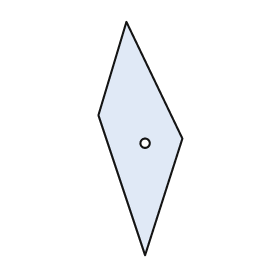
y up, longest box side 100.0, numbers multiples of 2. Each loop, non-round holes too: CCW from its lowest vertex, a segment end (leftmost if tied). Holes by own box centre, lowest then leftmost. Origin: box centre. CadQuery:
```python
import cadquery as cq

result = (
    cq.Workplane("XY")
    .moveTo(2.0, -50.0)
    .lineTo(18.0, 0.0)
    .lineTo(-6.0, 50.0)
    .lineTo(-18.0, 10.0)
    .close()
    .moveTo(2.0, -2.0)
    .circle(2.0)
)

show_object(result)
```